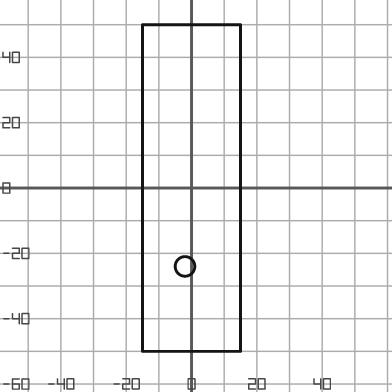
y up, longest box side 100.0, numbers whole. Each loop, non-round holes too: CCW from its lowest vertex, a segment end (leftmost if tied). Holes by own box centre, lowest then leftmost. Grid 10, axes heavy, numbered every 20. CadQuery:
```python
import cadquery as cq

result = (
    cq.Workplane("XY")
    .moveTo(-15.0, -50.0)
    .lineTo(15.0, -50.0)
    .lineTo(15.0, 50.0)
    .lineTo(-15.0, 50.0)
    .close()
    .moveTo(-2.0, -24.0)
    .circle(3.0)
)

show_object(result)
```